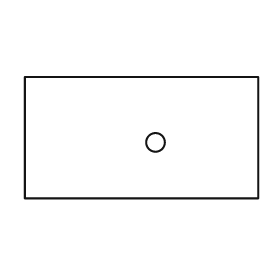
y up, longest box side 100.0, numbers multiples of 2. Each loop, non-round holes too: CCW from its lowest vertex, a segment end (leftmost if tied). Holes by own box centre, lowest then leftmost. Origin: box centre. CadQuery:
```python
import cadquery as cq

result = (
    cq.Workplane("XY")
    .moveTo(-50.0, -26.0)
    .lineTo(50.0, -26.0)
    .lineTo(50.0, 26.0)
    .lineTo(-50.0, 26.0)
    .close()
    .moveTo(6.0, -2.0)
    .circle(4.0)
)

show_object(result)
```